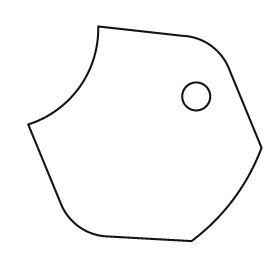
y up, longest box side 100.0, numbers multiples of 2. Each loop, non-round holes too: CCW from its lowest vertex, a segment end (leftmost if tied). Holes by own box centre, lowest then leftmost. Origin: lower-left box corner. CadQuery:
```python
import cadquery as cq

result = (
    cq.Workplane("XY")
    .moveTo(70.0, 0.0)
    .threePointArc((88.0, 18.0), (100.0, 40.0))
    .lineTo(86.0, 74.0)
    .threePointArc((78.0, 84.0), (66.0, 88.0))
    .lineTo(30.0, 92.0)
    .threePointArc((22.0, 66.0), (0.0, 50.0))
    .lineTo(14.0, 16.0)
    .threePointArc((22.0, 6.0), (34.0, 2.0))
    .close()
    .moveTo(72.0, 62.0)
    .circle(6.0)
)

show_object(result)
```